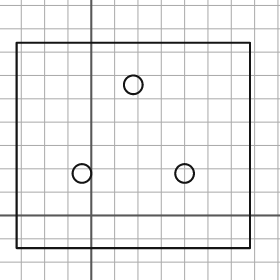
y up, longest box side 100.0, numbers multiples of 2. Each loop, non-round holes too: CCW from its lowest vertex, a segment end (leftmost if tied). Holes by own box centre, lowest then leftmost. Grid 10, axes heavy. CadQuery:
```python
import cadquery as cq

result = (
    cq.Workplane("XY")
    .moveTo(-32.0, -14.0)
    .lineTo(68.0, -14.0)
    .lineTo(68.0, 74.0)
    .lineTo(-32.0, 74.0)
    .close()
    .moveTo(-4.0, 18.0)
    .circle(4.0)
    .moveTo(40.0, 18.0)
    .circle(4.0)
    .moveTo(18.0, 56.0)
    .circle(4.0)
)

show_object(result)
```